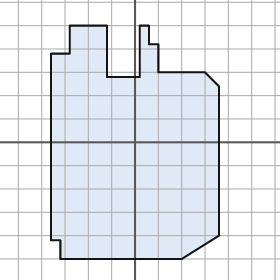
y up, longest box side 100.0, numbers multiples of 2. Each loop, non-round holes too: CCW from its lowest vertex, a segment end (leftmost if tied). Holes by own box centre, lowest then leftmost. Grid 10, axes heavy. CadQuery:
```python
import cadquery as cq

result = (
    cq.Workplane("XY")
    .moveTo(-32.0, -50.0)
    .lineTo(20.0, -50.0)
    .lineTo(36.0, -40.0)
    .lineTo(36.0, 24.0)
    .lineTo(30.0, 30.0)
    .lineTo(10.0, 30.0)
    .lineTo(10.0, 42.0)
    .lineTo(6.0, 42.0)
    .lineTo(6.0, 50.0)
    .lineTo(2.0, 50.0)
    .lineTo(2.0, 28.0)
    .lineTo(-12.0, 28.0)
    .lineTo(-12.0, 50.0)
    .lineTo(-28.0, 50.0)
    .lineTo(-28.0, 38.0)
    .lineTo(-36.0, 38.0)
    .lineTo(-36.0, -42.0)
    .lineTo(-32.0, -42.0)
    .close()
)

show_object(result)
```